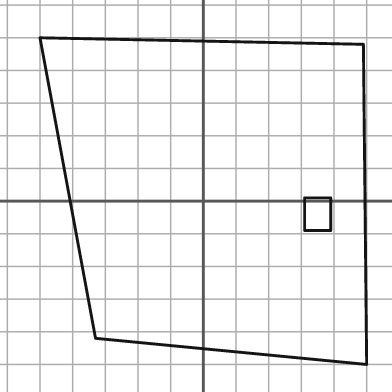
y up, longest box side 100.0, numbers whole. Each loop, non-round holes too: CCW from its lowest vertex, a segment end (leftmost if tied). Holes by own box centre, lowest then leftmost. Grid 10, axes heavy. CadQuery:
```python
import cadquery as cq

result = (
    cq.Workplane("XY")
    .moveTo(50.0, -50.0)
    .lineTo(49.0, 48.0)
    .lineTo(-50.0, 50.0)
    .lineTo(-33.0, -42.0)
    .close()
    .moveTo(31.0, -9.0)
    .lineTo(39.0, -9.0)
    .lineTo(39.0, 1.0)
    .lineTo(31.0, 1.0)
    .close()
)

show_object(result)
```